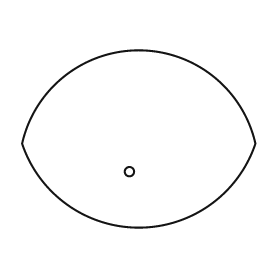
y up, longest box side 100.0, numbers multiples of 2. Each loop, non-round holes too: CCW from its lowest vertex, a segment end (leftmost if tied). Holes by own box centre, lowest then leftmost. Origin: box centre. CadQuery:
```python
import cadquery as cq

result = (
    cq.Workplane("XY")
    .moveTo(-50.0, -2.0)
    .threePointArc((0.0, -38.0), (50.0, -2.0))
    .threePointArc((0.0, 38.0), (-50.0, -2.0))
    .close()
    .moveTo(-4.0, -14.0)
    .circle(2.0)
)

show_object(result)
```